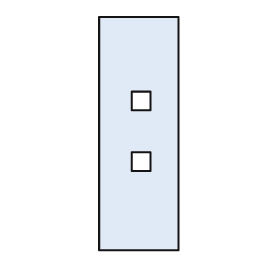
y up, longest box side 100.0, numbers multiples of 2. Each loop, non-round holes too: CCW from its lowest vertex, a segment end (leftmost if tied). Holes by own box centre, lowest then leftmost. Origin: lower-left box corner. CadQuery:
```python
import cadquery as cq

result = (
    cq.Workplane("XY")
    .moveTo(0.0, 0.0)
    .lineTo(34.0, 0.0)
    .lineTo(34.0, 100.0)
    .lineTo(0.0, 100.0)
    .close()
    .moveTo(14.0, 34.0)
    .lineTo(22.0, 34.0)
    .lineTo(22.0, 42.0)
    .lineTo(14.0, 42.0)
    .close()
    .moveTo(14.0, 60.0)
    .lineTo(22.0, 60.0)
    .lineTo(22.0, 68.0)
    .lineTo(14.0, 68.0)
    .close()
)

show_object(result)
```